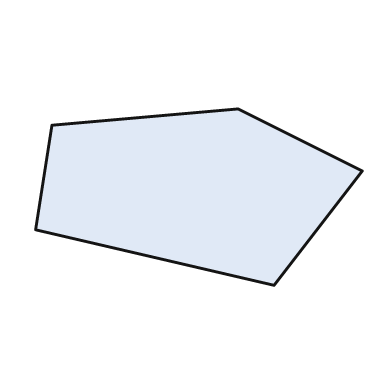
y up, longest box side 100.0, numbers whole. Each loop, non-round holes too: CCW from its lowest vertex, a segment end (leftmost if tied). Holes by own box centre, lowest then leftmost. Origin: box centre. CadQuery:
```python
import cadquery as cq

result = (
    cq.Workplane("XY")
    .moveTo(23.0, -27.0)
    .lineTo(50.0, 8.0)
    .lineTo(12.0, 27.0)
    .lineTo(-45.0, 22.0)
    .lineTo(-50.0, -10.0)
    .close()
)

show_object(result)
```